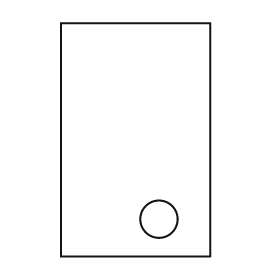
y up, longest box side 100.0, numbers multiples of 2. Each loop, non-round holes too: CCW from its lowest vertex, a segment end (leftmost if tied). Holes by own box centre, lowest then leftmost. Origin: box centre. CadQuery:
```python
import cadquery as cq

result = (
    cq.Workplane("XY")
    .moveTo(-32.0, -50.0)
    .lineTo(32.0, -50.0)
    .lineTo(32.0, 50.0)
    .lineTo(-32.0, 50.0)
    .close()
    .moveTo(10.0, -34.0)
    .circle(8.0)
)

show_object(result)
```